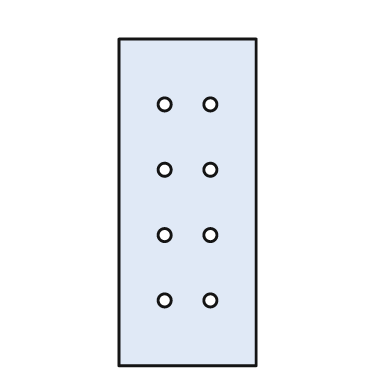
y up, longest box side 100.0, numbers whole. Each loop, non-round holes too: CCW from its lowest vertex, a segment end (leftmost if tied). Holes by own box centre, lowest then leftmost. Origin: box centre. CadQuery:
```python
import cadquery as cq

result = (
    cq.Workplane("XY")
    .moveTo(-21.0, -50.0)
    .lineTo(21.0, -50.0)
    .lineTo(21.0, 50.0)
    .lineTo(-21.0, 50.0)
    .close()
    .moveTo(-7.0, -30.0)
    .circle(2.0)
    .moveTo(7.0, -30.0)
    .circle(2.0)
    .moveTo(-7.0, -10.0)
    .circle(2.0)
    .moveTo(7.0, -10.0)
    .circle(2.0)
    .moveTo(-7.0, 10.0)
    .circle(2.0)
    .moveTo(7.0, 10.0)
    .circle(2.0)
    .moveTo(-7.0, 30.0)
    .circle(2.0)
    .moveTo(7.0, 30.0)
    .circle(2.0)
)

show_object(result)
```